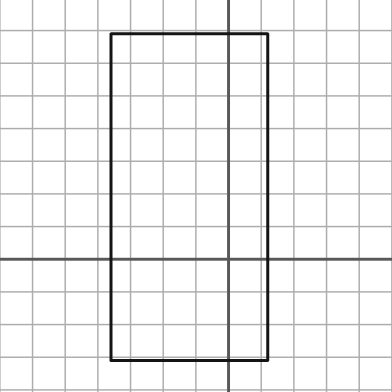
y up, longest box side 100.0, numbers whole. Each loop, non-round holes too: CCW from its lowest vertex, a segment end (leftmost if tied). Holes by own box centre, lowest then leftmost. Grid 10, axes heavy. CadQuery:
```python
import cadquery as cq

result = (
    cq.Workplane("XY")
    .moveTo(-36.0, -31.0)
    .lineTo(12.0, -31.0)
    .lineTo(12.0, 69.0)
    .lineTo(-36.0, 69.0)
    .close()
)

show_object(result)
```